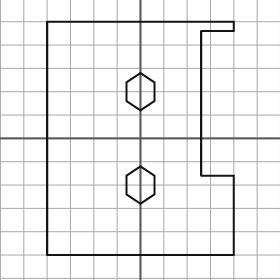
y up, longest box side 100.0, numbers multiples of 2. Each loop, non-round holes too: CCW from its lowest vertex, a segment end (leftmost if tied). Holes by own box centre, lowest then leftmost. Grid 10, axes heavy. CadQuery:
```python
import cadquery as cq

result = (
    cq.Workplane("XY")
    .moveTo(-40.0, -50.0)
    .lineTo(40.0, -50.0)
    .lineTo(40.0, -16.0)
    .lineTo(26.0, -16.0)
    .lineTo(26.0, 46.0)
    .lineTo(40.0, 46.0)
    .lineTo(40.0, 50.0)
    .lineTo(-40.0, 50.0)
    .close()
    .moveTo(0.0, -28.0)
    .lineTo(6.0, -24.0)
    .lineTo(6.0, -16.0)
    .lineTo(0.0, -12.0)
    .lineTo(-6.0, -16.0)
    .lineTo(-6.0, -24.0)
    .close()
    .moveTo(0.0, 12.0)
    .lineTo(6.0, 16.0)
    .lineTo(6.0, 24.0)
    .lineTo(0.0, 28.0)
    .lineTo(-6.0, 24.0)
    .lineTo(-6.0, 16.0)
    .close()
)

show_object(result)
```